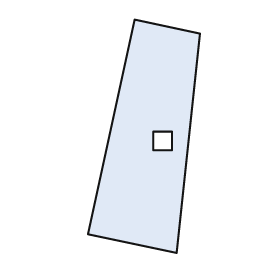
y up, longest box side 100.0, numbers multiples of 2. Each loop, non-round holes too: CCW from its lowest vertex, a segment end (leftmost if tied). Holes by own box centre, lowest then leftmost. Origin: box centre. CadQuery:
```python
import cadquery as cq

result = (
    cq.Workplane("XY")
    .moveTo(14.0, -50.0)
    .lineTo(24.0, 44.0)
    .lineTo(-4.0, 50.0)
    .lineTo(-24.0, -42.0)
    .close()
    .moveTo(4.0, -6.0)
    .lineTo(12.0, -6.0)
    .lineTo(12.0, 2.0)
    .lineTo(4.0, 2.0)
    .close()
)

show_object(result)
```